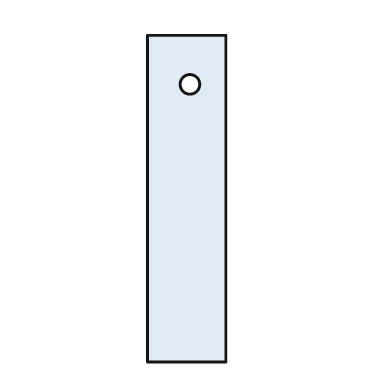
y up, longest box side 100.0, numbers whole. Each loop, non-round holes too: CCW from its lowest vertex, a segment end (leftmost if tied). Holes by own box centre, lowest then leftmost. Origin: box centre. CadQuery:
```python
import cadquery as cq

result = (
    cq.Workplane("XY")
    .moveTo(-12.0, -50.0)
    .lineTo(12.0, -50.0)
    .lineTo(12.0, 50.0)
    .lineTo(-12.0, 50.0)
    .close()
    .moveTo(1.0, 35.0)
    .circle(3.0)
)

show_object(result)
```